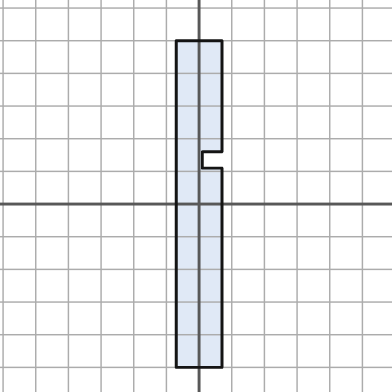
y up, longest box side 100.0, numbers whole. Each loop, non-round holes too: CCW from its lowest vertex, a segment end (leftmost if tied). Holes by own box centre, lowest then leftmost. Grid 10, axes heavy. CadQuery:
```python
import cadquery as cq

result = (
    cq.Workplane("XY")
    .moveTo(-7.0, -50.0)
    .lineTo(7.0, -50.0)
    .lineTo(7.0, 11.0)
    .lineTo(1.0, 11.0)
    .lineTo(1.0, 16.0)
    .lineTo(7.0, 16.0)
    .lineTo(7.0, 50.0)
    .lineTo(-7.0, 50.0)
    .close()
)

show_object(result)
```